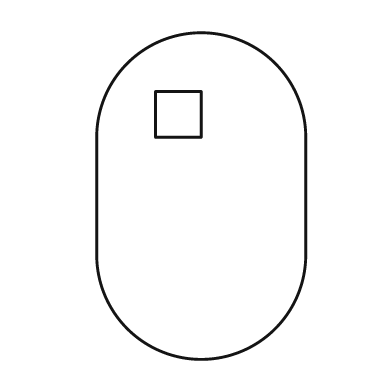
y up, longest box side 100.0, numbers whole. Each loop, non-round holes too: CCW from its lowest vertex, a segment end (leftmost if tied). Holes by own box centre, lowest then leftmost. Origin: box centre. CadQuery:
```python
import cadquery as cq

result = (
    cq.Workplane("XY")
    .moveTo(-32.0, -18.0)
    .threePointArc((0.0, -50.0), (32.0, -18.0))
    .lineTo(32.0, 18.0)
    .threePointArc((0.0, 50.0), (-32.0, 18.0))
    .close()
    .moveTo(-14.0, 18.0)
    .lineTo(0.0, 18.0)
    .lineTo(0.0, 32.0)
    .lineTo(-14.0, 32.0)
    .close()
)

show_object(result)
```